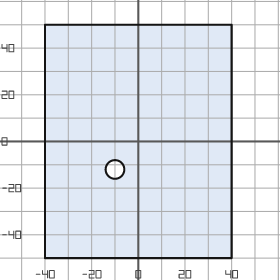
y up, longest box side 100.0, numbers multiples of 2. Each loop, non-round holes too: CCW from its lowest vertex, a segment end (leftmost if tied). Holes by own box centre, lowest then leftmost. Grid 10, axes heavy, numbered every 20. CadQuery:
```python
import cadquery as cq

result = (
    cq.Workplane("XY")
    .moveTo(-40.0, -50.0)
    .lineTo(40.0, -50.0)
    .lineTo(40.0, 50.0)
    .lineTo(-40.0, 50.0)
    .close()
    .moveTo(-10.0, -12.0)
    .circle(4.0)
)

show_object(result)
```